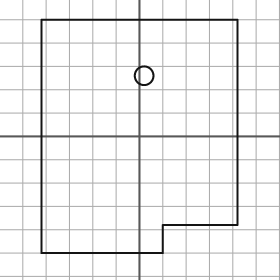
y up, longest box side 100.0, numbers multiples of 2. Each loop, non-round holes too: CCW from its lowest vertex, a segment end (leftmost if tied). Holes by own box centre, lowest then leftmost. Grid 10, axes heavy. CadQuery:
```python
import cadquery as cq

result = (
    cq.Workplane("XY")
    .moveTo(-42.0, -50.0)
    .lineTo(10.0, -50.0)
    .lineTo(10.0, -38.0)
    .lineTo(42.0, -38.0)
    .lineTo(42.0, 50.0)
    .lineTo(-42.0, 50.0)
    .close()
    .moveTo(2.0, 26.0)
    .circle(4.0)
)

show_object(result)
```